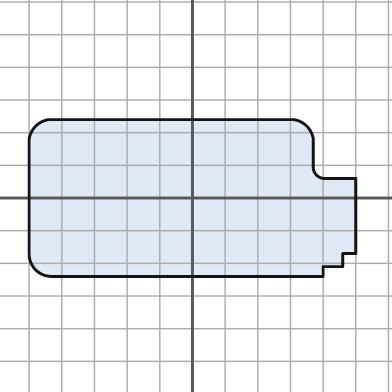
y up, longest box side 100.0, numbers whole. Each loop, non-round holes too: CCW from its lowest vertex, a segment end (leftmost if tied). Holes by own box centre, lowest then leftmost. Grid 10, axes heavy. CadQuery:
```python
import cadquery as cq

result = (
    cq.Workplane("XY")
    .moveTo(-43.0, -24.0)
    .lineTo(40.0, -24.0)
    .lineTo(40.0, -21.0)
    .lineTo(46.0, -21.0)
    .lineTo(46.0, -17.0)
    .lineTo(50.0, -17.0)
    .lineTo(50.0, 6.0)
    .lineTo(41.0, 6.0)
    .threePointArc((38.0, 7.0), (37.0, 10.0))
    .lineTo(37.0, 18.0)
    .threePointArc((35.0, 22.0), (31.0, 24.0))
    .lineTo(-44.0, 24.0)
    .threePointArc((-48.0, 22.0), (-50.0, 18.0))
    .lineTo(-50.0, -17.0)
    .threePointArc((-48.0, -22.0), (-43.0, -24.0))
    .close()
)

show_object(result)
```